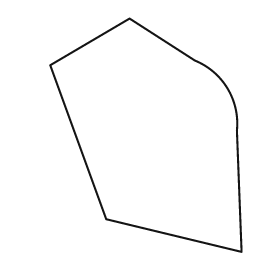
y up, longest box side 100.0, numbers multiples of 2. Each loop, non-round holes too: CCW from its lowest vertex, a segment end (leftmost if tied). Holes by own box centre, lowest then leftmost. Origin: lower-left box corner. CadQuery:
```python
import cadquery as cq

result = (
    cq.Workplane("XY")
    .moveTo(82.0, 0.0)
    .lineTo(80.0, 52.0)
    .threePointArc((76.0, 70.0), (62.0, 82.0))
    .lineTo(34.0, 100.0)
    .lineTo(0.0, 80.0)
    .lineTo(24.0, 14.0)
    .close()
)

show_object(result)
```